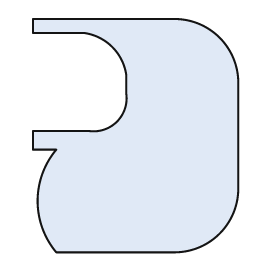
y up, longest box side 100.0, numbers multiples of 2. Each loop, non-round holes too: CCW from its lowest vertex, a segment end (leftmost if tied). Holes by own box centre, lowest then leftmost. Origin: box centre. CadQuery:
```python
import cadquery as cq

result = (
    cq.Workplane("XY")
    .moveTo(-34.0, -50.0)
    .lineTo(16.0, -50.0)
    .threePointArc((36.0, -42.0), (44.0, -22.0))
    .lineTo(44.0, 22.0)
    .threePointArc((36.0, 42.0), (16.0, 50.0))
    .lineTo(-44.0, 50.0)
    .lineTo(-44.0, 44.0)
    .lineTo(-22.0, 44.0)
    .threePointArc((-10.0, 38.0), (-4.0, 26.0))
    .lineTo(-4.0, 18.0)
    .threePointArc((-8.0, 6.0), (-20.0, 2.0))
    .lineTo(-44.0, 2.0)
    .lineTo(-44.0, -6.0)
    .lineTo(-34.0, -6.0)
    .threePointArc((-42.0, -28.0), (-34.0, -50.0))
    .close()
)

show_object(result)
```